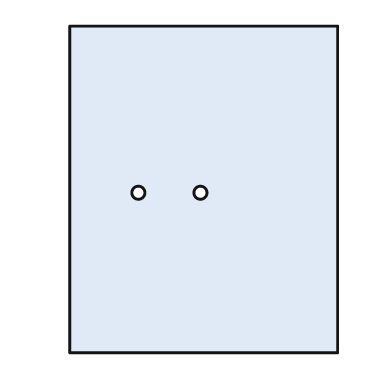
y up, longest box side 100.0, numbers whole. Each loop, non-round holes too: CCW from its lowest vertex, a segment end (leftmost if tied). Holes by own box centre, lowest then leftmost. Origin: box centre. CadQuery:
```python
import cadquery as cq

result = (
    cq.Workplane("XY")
    .moveTo(-41.0, -50.0)
    .lineTo(41.0, -50.0)
    .lineTo(41.0, 50.0)
    .lineTo(-41.0, 50.0)
    .close()
    .moveTo(-20.0, -1.0)
    .circle(2.0)
    .moveTo(-1.0, -1.0)
    .circle(2.0)
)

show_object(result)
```